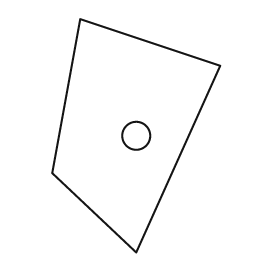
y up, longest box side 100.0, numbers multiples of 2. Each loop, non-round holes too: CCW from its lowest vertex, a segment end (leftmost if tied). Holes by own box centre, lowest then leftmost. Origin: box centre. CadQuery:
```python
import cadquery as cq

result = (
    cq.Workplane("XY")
    .moveTo(0.0, -50.0)
    .lineTo(36.0, 30.0)
    .lineTo(-24.0, 50.0)
    .lineTo(-36.0, -16.0)
    .close()
    .moveTo(0.0, 0.0)
    .circle(6.0)
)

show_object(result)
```